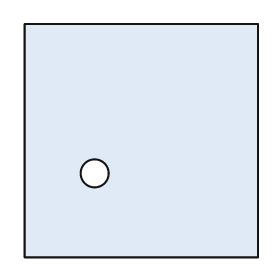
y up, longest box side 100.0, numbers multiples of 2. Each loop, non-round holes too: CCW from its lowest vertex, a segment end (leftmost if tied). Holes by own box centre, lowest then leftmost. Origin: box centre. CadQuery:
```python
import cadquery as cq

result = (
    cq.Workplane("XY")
    .moveTo(-50.0, -50.0)
    .lineTo(50.0, -50.0)
    .lineTo(50.0, 50.0)
    .lineTo(-50.0, 50.0)
    .close()
    .moveTo(-20.0, -14.0)
    .circle(6.0)
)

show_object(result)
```